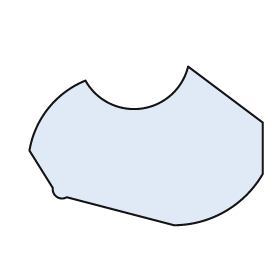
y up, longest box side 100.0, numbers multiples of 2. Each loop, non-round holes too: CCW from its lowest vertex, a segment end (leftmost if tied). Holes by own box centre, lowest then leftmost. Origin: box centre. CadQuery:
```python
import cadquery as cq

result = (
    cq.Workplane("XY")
    .moveTo(12.0, -34.0)
    .threePointArc((34.0, -28.0), (50.0, -12.0))
    .lineTo(50.0, 10.0)
    .lineTo(18.0, 34.0)
    .threePointArc((-2.0, 16.0), (-26.0, 28.0))
    .threePointArc((-42.0, 16.0), (-50.0, -2.0))
    .lineTo(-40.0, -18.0)
    .threePointArc((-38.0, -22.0), (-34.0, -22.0))
    .close()
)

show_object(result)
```